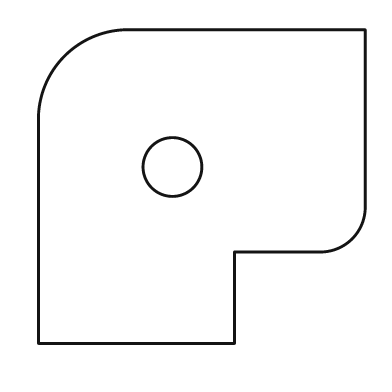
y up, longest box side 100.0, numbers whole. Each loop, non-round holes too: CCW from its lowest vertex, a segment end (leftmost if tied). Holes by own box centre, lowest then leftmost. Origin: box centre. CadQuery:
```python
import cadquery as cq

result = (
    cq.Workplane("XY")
    .moveTo(-50.0, -48.0)
    .lineTo(10.0, -48.0)
    .lineTo(10.0, -20.0)
    .lineTo(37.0, -20.0)
    .threePointArc((46.0, -16.0), (50.0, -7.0))
    .lineTo(50.0, 48.0)
    .lineTo(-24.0, 48.0)
    .threePointArc((-42.0, 40.0), (-50.0, 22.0))
    .close()
    .moveTo(-9.0, 6.0)
    .circle(9.0)
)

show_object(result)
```